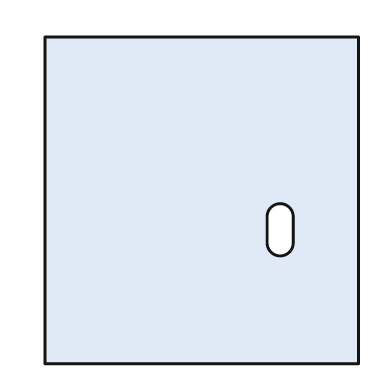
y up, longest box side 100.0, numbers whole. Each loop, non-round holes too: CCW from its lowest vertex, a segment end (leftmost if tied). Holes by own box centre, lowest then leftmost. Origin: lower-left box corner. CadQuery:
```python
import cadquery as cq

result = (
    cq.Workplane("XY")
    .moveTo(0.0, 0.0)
    .lineTo(96.0, 0.0)
    .lineTo(96.0, 100.0)
    .lineTo(0.0, 100.0)
    .close()
    .moveTo(68.0, 37.0)
    .threePointArc((72.0, 33.0), (76.0, 37.0))
    .lineTo(76.0, 45.0)
    .threePointArc((72.0, 49.0), (68.0, 45.0))
    .close()
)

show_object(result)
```